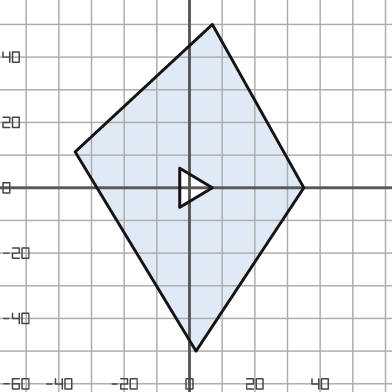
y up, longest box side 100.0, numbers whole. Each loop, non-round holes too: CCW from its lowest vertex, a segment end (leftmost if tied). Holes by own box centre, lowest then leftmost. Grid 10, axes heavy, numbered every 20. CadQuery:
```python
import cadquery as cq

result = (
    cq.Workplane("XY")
    .moveTo(2.0, -50.0)
    .lineTo(35.0, 0.0)
    .lineTo(7.0, 50.0)
    .lineTo(-35.0, 11.0)
    .close()
    .moveTo(-3.0, -6.0)
    .lineTo(7.0, 0.0)
    .lineTo(-3.0, 6.0)
    .close()
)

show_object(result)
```